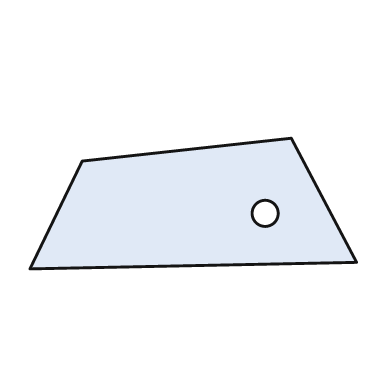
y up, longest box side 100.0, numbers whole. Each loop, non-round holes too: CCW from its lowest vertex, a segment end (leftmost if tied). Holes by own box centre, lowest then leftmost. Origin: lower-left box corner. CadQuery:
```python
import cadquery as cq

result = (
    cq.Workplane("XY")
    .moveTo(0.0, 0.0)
    .lineTo(100.0, 2.0)
    .lineTo(80.0, 40.0)
    .lineTo(16.0, 33.0)
    .close()
    .moveTo(72.0, 17.0)
    .circle(4.0)
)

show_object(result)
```